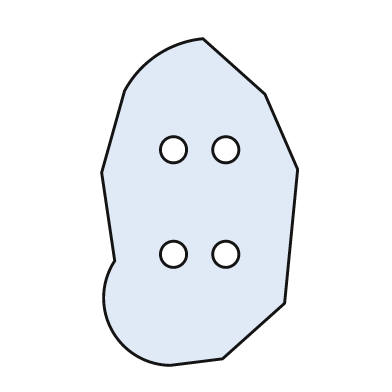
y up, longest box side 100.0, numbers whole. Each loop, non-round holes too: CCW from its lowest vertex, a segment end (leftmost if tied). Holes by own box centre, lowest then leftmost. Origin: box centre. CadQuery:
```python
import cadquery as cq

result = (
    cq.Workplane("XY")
    .moveTo(-9.0, -50.0)
    .lineTo(7.0, -48.0)
    .lineTo(26.0, -31.0)
    .lineTo(30.0, 10.0)
    .lineTo(20.0, 33.0)
    .lineTo(1.0, 50.0)
    .threePointArc((-13.0, 45.0), (-23.0, 34.0))
    .lineTo(-30.0, 9.0)
    .lineTo(-26.0, -18.0)
    .threePointArc((-27.0, -39.0), (-9.0, -50.0))
    .close()
    .moveTo(-8.0, -16.0)
    .circle(4.0)
    .moveTo(8.0, -16.0)
    .circle(4.0)
    .moveTo(-8.0, 16.0)
    .circle(4.0)
    .moveTo(8.0, 16.0)
    .circle(4.0)
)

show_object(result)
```